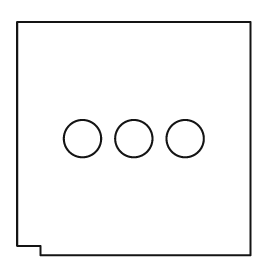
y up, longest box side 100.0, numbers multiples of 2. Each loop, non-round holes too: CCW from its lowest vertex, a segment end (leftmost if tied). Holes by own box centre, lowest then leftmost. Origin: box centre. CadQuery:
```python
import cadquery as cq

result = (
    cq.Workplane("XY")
    .moveTo(-40.0, -50.0)
    .lineTo(50.0, -50.0)
    .lineTo(50.0, 50.0)
    .lineTo(-50.0, 50.0)
    .lineTo(-50.0, -46.0)
    .lineTo(-40.0, -46.0)
    .close()
    .moveTo(-22.0, 0.0)
    .circle(8.0)
    .moveTo(0.0, 0.0)
    .circle(8.0)
    .moveTo(22.0, 0.0)
    .circle(8.0)
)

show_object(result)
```